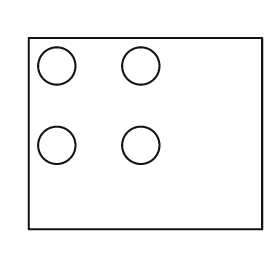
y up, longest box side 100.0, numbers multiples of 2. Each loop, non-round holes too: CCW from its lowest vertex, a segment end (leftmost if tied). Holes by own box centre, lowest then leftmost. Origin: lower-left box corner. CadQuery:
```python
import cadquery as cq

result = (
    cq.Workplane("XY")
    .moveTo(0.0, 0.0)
    .lineTo(100.0, 0.0)
    .lineTo(100.0, 82.0)
    .lineTo(0.0, 82.0)
    .close()
    .moveTo(12.0, 36.0)
    .circle(8.0)
    .moveTo(48.0, 36.0)
    .circle(8.0)
    .moveTo(12.0, 70.0)
    .circle(8.0)
    .moveTo(48.0, 70.0)
    .circle(8.0)
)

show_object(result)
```